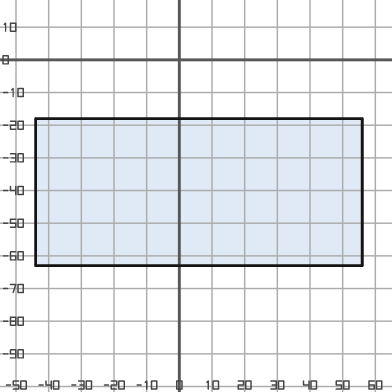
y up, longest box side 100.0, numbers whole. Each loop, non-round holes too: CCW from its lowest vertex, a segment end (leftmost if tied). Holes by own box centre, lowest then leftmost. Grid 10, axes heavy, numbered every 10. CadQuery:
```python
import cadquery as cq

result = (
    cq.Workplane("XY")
    .moveTo(-44.0, -63.0)
    .lineTo(56.0, -63.0)
    .lineTo(56.0, -18.0)
    .lineTo(-44.0, -18.0)
    .close()
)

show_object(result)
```